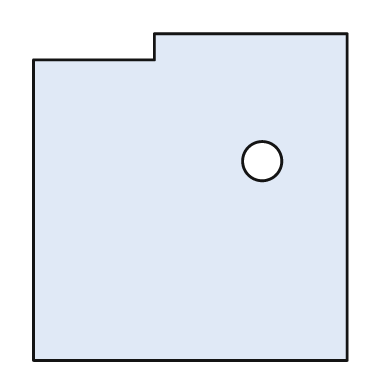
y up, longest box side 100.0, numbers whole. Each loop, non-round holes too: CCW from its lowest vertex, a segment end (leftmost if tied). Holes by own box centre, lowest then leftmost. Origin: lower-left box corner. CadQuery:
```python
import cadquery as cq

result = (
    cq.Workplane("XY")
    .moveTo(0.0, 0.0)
    .lineTo(96.0, 0.0)
    .lineTo(96.0, 100.0)
    .lineTo(37.0, 100.0)
    .lineTo(37.0, 92.0)
    .lineTo(0.0, 92.0)
    .close()
    .moveTo(70.0, 61.0)
    .circle(6.0)
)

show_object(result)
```